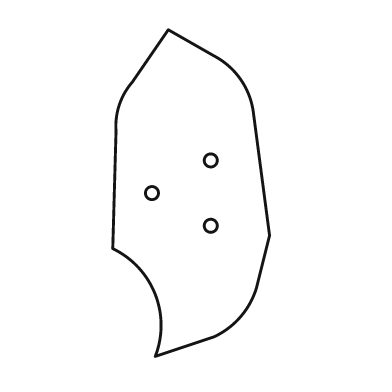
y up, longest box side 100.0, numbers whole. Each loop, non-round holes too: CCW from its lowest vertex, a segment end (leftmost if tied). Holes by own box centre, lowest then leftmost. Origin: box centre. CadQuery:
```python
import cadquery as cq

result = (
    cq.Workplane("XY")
    .moveTo(-11.0, -50.0)
    .lineTo(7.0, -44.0)
    .threePointArc((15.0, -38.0), (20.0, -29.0))
    .lineTo(24.0, -13.0)
    .lineTo(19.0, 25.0)
    .threePointArc((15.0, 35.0), (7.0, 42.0))
    .lineTo(-7.0, 50.0)
    .lineTo(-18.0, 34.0)
    .threePointArc((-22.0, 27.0), (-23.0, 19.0))
    .lineTo(-24.0, -17.0)
    .threePointArc((-11.0, -31.0), (-11.0, -50.0))
    .close()
    .moveTo(6.0, -10.0)
    .circle(2.0)
    .moveTo(-12.0, 0.0)
    .circle(2.0)
    .moveTo(6.0, 10.0)
    .circle(2.0)
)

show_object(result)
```